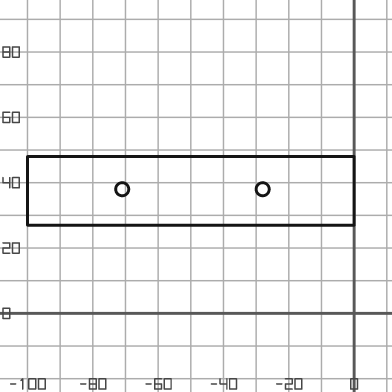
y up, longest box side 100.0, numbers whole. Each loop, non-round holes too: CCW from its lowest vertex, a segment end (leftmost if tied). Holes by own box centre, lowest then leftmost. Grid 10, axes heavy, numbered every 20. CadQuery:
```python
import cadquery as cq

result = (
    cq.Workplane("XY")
    .moveTo(-100.0, 27.0)
    .lineTo(0.0, 27.0)
    .lineTo(0.0, 48.0)
    .lineTo(-100.0, 48.0)
    .close()
    .moveTo(-71.0, 38.0)
    .circle(2.0)
    .moveTo(-28.0, 38.0)
    .circle(2.0)
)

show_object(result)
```